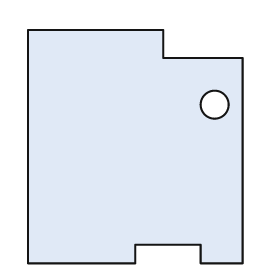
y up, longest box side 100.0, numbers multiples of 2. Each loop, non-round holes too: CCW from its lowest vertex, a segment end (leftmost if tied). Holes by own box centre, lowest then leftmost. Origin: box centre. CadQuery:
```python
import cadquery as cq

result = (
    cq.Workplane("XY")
    .moveTo(-46.0, -50.0)
    .lineTo(0.0, -50.0)
    .lineTo(0.0, -42.0)
    .lineTo(28.0, -42.0)
    .lineTo(28.0, -50.0)
    .lineTo(46.0, -50.0)
    .lineTo(46.0, 38.0)
    .lineTo(12.0, 38.0)
    .lineTo(12.0, 50.0)
    .lineTo(-46.0, 50.0)
    .close()
    .moveTo(34.0, 18.0)
    .circle(6.0)
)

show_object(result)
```